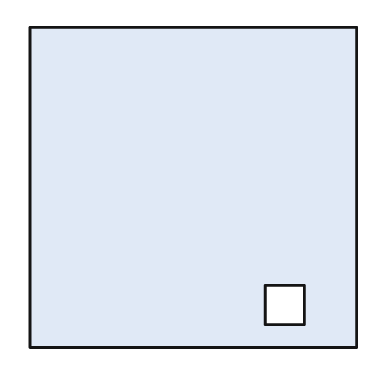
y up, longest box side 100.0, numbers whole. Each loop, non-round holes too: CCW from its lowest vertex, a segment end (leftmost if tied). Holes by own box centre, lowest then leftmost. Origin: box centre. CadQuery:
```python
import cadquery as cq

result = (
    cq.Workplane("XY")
    .moveTo(-50.0, -49.0)
    .lineTo(50.0, -49.0)
    .lineTo(50.0, 49.0)
    .lineTo(-50.0, 49.0)
    .close()
    .moveTo(22.0, -42.0)
    .lineTo(34.0, -42.0)
    .lineTo(34.0, -30.0)
    .lineTo(22.0, -30.0)
    .close()
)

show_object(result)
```